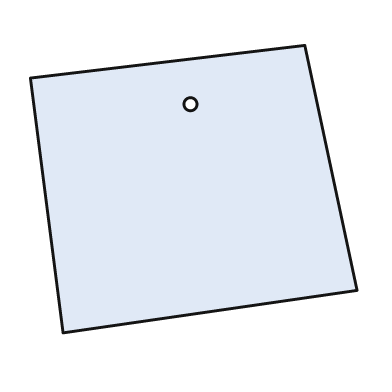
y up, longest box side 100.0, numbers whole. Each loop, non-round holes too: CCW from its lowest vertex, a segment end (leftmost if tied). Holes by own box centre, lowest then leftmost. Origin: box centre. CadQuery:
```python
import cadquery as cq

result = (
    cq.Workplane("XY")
    .moveTo(-40.0, -44.0)
    .lineTo(50.0, -31.0)
    .lineTo(34.0, 44.0)
    .lineTo(-50.0, 34.0)
    .close()
    .moveTo(-1.0, 26.0)
    .circle(2.0)
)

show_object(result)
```